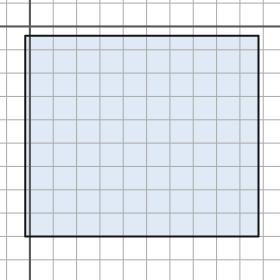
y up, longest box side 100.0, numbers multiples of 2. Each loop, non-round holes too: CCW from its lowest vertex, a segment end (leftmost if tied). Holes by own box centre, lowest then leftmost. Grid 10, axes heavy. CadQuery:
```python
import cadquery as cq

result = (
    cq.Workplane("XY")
    .moveTo(-2.0, -90.0)
    .lineTo(98.0, -90.0)
    .lineTo(98.0, -4.0)
    .lineTo(-2.0, -4.0)
    .close()
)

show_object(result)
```